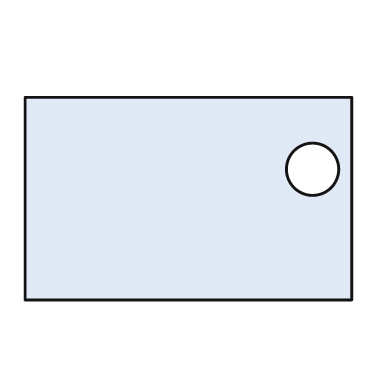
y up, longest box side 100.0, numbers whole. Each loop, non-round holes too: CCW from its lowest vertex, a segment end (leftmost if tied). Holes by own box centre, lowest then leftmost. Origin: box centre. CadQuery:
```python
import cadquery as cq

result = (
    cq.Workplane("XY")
    .moveTo(-50.0, -31.0)
    .lineTo(50.0, -31.0)
    .lineTo(50.0, 31.0)
    .lineTo(-50.0, 31.0)
    .close()
    .moveTo(38.0, 9.0)
    .circle(8.0)
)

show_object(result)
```